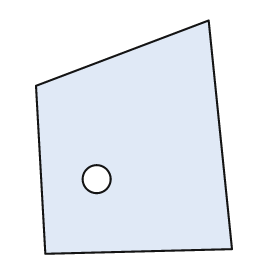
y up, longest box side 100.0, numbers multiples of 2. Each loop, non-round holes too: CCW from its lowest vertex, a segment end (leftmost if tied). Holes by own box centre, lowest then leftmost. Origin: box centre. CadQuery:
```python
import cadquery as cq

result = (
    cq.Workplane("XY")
    .moveTo(-38.0, -50.0)
    .lineTo(42.0, -48.0)
    .lineTo(32.0, 50.0)
    .lineTo(-42.0, 22.0)
    .close()
    .moveTo(-16.0, -18.0)
    .circle(6.0)
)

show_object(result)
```